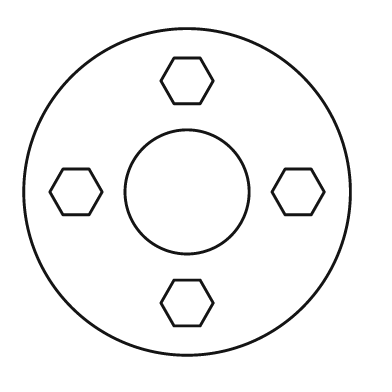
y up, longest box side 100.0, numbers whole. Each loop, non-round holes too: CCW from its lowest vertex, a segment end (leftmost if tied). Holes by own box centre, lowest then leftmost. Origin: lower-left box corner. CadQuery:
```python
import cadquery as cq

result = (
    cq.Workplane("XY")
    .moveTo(50.0, 50.0)
    .circle(50.0)
    .moveTo(46.0, 9.0)
    .lineTo(54.0, 9.0)
    .lineTo(58.0, 16.0)
    .lineTo(54.0, 23.0)
    .lineTo(46.0, 23.0)
    .lineTo(42.0, 16.0)
    .close()
    .moveTo(12.0, 43.0)
    .lineTo(20.0, 43.0)
    .lineTo(24.0, 50.0)
    .lineTo(20.0, 57.0)
    .lineTo(12.0, 57.0)
    .lineTo(8.0, 50.0)
    .close()
    .moveTo(50.0, 50.0)
    .circle(19.0)
    .moveTo(80.0, 43.0)
    .lineTo(88.0, 43.0)
    .lineTo(92.0, 50.0)
    .lineTo(88.0, 57.0)
    .lineTo(80.0, 57.0)
    .lineTo(76.0, 50.0)
    .close()
    .moveTo(46.0, 77.0)
    .lineTo(54.0, 77.0)
    .lineTo(58.0, 84.0)
    .lineTo(54.0, 91.0)
    .lineTo(46.0, 91.0)
    .lineTo(42.0, 84.0)
    .close()
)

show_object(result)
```